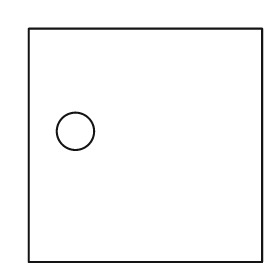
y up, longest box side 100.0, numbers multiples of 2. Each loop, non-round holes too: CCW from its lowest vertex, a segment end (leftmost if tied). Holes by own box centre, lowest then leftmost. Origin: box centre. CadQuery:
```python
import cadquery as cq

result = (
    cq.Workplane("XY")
    .moveTo(-50.0, -50.0)
    .lineTo(50.0, -50.0)
    .lineTo(50.0, 50.0)
    .lineTo(-50.0, 50.0)
    .close()
    .moveTo(-30.0, 6.0)
    .circle(8.0)
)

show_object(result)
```